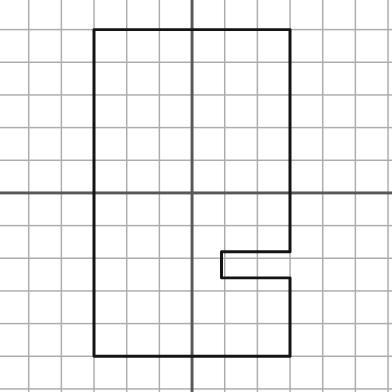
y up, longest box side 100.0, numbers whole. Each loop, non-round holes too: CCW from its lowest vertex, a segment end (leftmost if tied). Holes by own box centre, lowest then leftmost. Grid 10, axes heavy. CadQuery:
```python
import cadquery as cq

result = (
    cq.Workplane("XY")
    .moveTo(-30.0, -50.0)
    .lineTo(30.0, -50.0)
    .lineTo(30.0, -26.0)
    .lineTo(9.0, -26.0)
    .lineTo(9.0, -18.0)
    .lineTo(30.0, -18.0)
    .lineTo(30.0, 50.0)
    .lineTo(-30.0, 50.0)
    .close()
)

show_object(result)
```